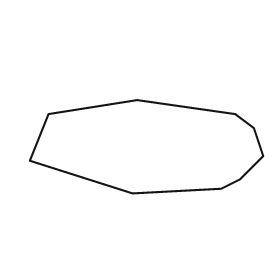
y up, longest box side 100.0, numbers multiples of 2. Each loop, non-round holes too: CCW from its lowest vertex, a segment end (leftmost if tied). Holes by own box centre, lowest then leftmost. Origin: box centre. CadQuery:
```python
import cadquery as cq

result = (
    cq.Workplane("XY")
    .moveTo(-6.0, -20.0)
    .lineTo(32.0, -18.0)
    .lineTo(40.0, -14.0)
    .lineTo(50.0, -4.0)
    .lineTo(46.0, 8.0)
    .lineTo(38.0, 14.0)
    .lineTo(-4.0, 20.0)
    .lineTo(-42.0, 14.0)
    .lineTo(-50.0, -6.0)
    .close()
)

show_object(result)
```